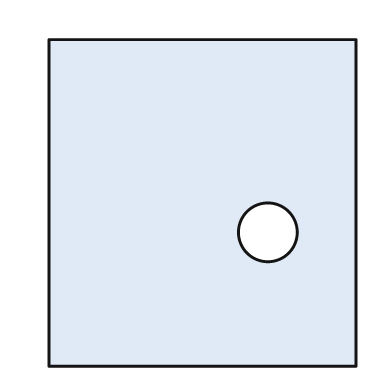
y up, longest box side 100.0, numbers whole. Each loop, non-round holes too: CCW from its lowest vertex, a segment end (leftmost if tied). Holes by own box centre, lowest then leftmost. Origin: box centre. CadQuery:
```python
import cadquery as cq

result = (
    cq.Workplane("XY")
    .moveTo(-47.0, -50.0)
    .lineTo(47.0, -50.0)
    .lineTo(47.0, 50.0)
    .lineTo(-47.0, 50.0)
    .close()
    .moveTo(20.0, -9.0)
    .circle(9.0)
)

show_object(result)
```